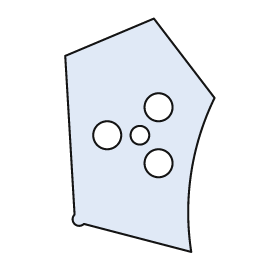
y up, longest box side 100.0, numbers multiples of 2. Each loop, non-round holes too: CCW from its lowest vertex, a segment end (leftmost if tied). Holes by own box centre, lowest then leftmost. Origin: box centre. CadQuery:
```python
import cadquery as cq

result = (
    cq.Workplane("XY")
    .moveTo(22.0, -50.0)
    .threePointArc((22.0, -16.0), (32.0, 16.0))
    .lineTo(6.0, 50.0)
    .lineTo(-32.0, 34.0)
    .lineTo(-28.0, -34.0)
    .threePointArc((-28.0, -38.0), (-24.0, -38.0))
    .close()
    .moveTo(8.0, -12.0)
    .circle(6.0)
    .moveTo(-14.0, 0.0)
    .circle(6.0)
    .moveTo(0.0, 0.0)
    .circle(4.0)
    .moveTo(8.0, 12.0)
    .circle(6.0)
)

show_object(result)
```